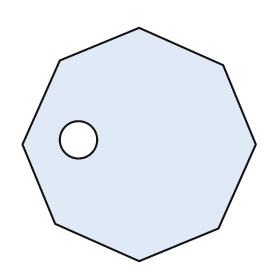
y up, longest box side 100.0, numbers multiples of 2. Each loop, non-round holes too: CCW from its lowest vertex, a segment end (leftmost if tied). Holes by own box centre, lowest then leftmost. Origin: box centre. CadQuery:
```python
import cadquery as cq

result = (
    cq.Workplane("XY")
    .moveTo(0.0, -50.0)
    .lineTo(34.0, -36.0)
    .lineTo(50.0, 0.0)
    .lineTo(36.0, 34.0)
    .lineTo(0.0, 50.0)
    .lineTo(-34.0, 36.0)
    .lineTo(-50.0, 0.0)
    .lineTo(-36.0, -34.0)
    .close()
    .moveTo(-26.0, 2.0)
    .circle(8.0)
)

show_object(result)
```